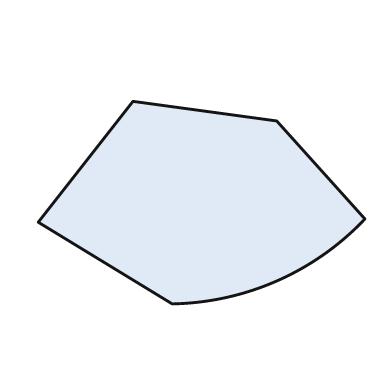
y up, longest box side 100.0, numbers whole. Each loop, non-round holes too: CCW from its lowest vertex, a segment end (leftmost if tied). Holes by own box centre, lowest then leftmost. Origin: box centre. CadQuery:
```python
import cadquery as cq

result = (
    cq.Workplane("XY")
    .moveTo(-9.0, -31.0)
    .threePointArc((23.0, -24.0), (50.0, -5.0))
    .lineTo(23.0, 25.0)
    .lineTo(-21.0, 31.0)
    .lineTo(-50.0, -6.0)
    .close()
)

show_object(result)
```